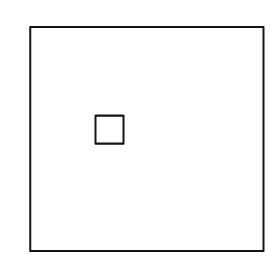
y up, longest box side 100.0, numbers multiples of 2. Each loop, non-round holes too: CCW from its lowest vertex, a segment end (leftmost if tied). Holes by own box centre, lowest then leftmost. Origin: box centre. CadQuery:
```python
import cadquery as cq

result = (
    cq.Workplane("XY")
    .moveTo(-50.0, -48.0)
    .lineTo(50.0, -48.0)
    .lineTo(50.0, 48.0)
    .lineTo(-50.0, 48.0)
    .close()
    .moveTo(-22.0, -2.0)
    .lineTo(-10.0, -2.0)
    .lineTo(-10.0, 10.0)
    .lineTo(-22.0, 10.0)
    .close()
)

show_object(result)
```